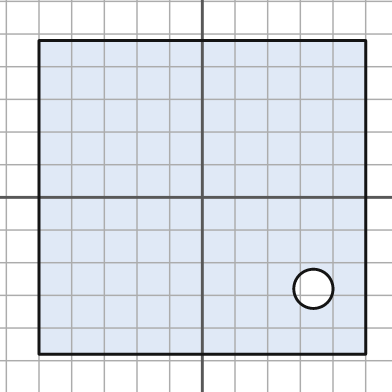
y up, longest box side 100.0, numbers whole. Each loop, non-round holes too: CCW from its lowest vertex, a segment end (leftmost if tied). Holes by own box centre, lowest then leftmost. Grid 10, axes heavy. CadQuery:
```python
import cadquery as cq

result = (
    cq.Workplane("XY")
    .moveTo(-50.0, -48.0)
    .lineTo(50.0, -48.0)
    .lineTo(50.0, 48.0)
    .lineTo(-50.0, 48.0)
    .close()
    .moveTo(34.0, -28.0)
    .circle(6.0)
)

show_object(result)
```